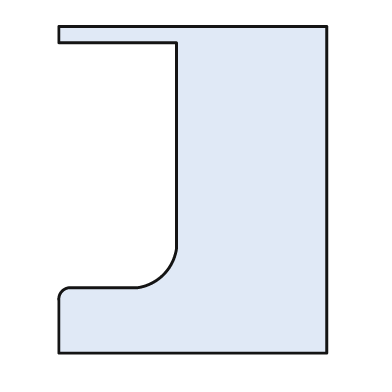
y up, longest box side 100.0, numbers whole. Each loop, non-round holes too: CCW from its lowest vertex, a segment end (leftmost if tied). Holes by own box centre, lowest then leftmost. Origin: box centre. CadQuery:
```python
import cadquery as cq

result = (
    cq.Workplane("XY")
    .moveTo(-41.0, -50.0)
    .lineTo(41.0, -50.0)
    .lineTo(41.0, 50.0)
    .lineTo(-41.0, 50.0)
    .lineTo(-41.0, 45.0)
    .lineTo(-5.0, 45.0)
    .lineTo(-5.0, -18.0)
    .threePointArc((-9.0, -26.0), (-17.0, -30.0))
    .lineTo(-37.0, -30.0)
    .threePointArc((-40.0, -31.0), (-41.0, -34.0))
    .close()
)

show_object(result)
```